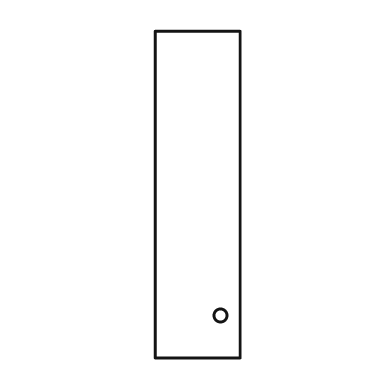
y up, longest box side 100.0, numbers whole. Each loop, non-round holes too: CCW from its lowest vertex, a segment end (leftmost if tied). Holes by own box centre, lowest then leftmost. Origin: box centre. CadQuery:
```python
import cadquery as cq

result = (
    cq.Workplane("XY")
    .moveTo(-13.0, -50.0)
    .lineTo(13.0, -50.0)
    .lineTo(13.0, 50.0)
    .lineTo(-13.0, 50.0)
    .close()
    .moveTo(7.0, -37.0)
    .circle(2.0)
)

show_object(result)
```